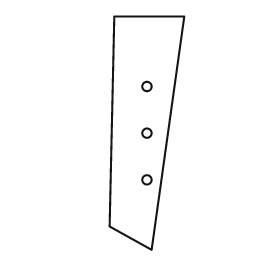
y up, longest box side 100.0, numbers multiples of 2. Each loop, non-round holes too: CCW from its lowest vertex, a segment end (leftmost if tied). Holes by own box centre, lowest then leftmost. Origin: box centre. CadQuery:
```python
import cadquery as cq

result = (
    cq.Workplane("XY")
    .moveTo(2.0, -50.0)
    .lineTo(16.0, 50.0)
    .lineTo(-14.0, 50.0)
    .lineTo(-16.0, -40.0)
    .close()
    .moveTo(0.0, -20.0)
    .circle(2.0)
    .moveTo(0.0, 0.0)
    .circle(2.0)
    .moveTo(0.0, 20.0)
    .circle(2.0)
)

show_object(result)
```